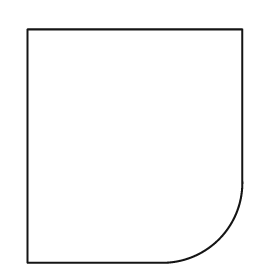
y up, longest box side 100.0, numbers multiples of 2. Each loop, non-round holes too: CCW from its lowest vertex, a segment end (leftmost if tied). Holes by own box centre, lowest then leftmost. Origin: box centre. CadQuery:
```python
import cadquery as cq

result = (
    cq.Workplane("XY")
    .moveTo(-46.0, -50.0)
    .lineTo(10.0, -50.0)
    .threePointArc((36.0, -40.0), (46.0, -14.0))
    .lineTo(46.0, 50.0)
    .lineTo(-46.0, 50.0)
    .close()
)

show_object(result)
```